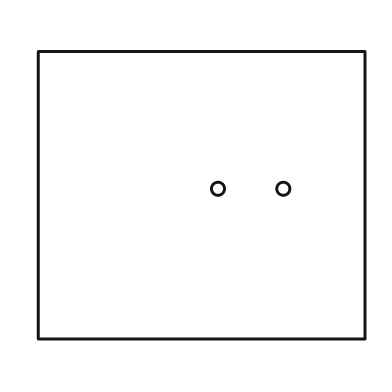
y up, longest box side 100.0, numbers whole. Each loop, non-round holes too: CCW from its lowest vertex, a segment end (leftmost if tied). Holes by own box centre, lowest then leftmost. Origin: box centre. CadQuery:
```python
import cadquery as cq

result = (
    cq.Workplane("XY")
    .moveTo(-50.0, -44.0)
    .lineTo(50.0, -44.0)
    .lineTo(50.0, 44.0)
    .lineTo(-50.0, 44.0)
    .close()
    .moveTo(5.0, 2.0)
    .circle(2.0)
    .moveTo(25.0, 2.0)
    .circle(2.0)
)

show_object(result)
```